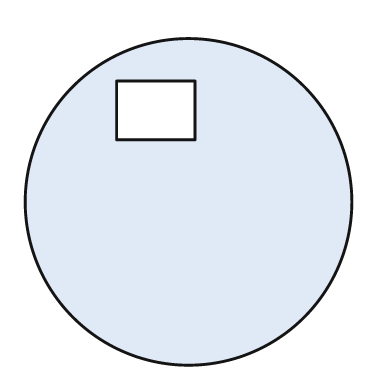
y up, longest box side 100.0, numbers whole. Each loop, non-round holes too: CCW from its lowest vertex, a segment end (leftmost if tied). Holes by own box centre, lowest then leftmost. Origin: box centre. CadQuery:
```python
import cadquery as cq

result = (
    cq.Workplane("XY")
    .moveTo(0.0, 0.0)
    .circle(50.0)
    .moveTo(-22.0, 19.0)
    .lineTo(2.0, 19.0)
    .lineTo(2.0, 37.0)
    .lineTo(-22.0, 37.0)
    .close()
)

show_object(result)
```